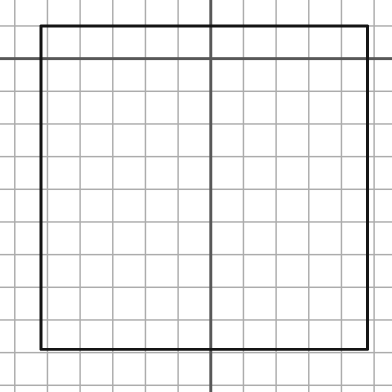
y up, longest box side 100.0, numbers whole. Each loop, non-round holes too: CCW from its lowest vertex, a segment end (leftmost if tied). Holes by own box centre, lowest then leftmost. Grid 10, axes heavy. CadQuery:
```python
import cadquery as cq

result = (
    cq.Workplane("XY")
    .moveTo(-52.0, -89.0)
    .lineTo(48.0, -89.0)
    .lineTo(48.0, 10.0)
    .lineTo(-52.0, 10.0)
    .close()
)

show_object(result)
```